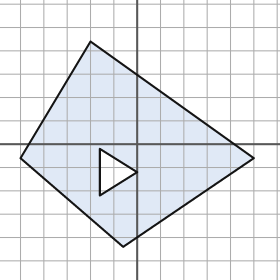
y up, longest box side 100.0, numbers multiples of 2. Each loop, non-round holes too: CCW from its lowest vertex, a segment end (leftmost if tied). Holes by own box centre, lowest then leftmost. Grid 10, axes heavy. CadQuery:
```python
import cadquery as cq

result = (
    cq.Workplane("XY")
    .moveTo(-6.0, -44.0)
    .lineTo(50.0, -6.0)
    .lineTo(-20.0, 44.0)
    .lineTo(-50.0, -6.0)
    .close()
    .moveTo(-16.0, -22.0)
    .lineTo(0.0, -12.0)
    .lineTo(-16.0, -2.0)
    .close()
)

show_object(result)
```